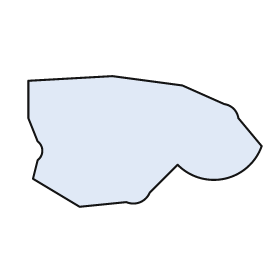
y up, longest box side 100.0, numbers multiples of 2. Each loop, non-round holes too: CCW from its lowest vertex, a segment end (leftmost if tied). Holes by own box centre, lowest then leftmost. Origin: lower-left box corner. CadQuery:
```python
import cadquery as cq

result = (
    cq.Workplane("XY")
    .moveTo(22.0, 0.0)
    .lineTo(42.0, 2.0)
    .threePointArc((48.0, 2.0), (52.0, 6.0))
    .lineTo(64.0, 18.0)
    .threePointArc((84.0, 12.0), (100.0, 26.0))
    .lineTo(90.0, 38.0)
    .threePointArc((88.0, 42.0), (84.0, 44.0))
    .lineTo(66.0, 52.0)
    .lineTo(36.0, 56.0)
    .lineTo(0.0, 54.0)
    .lineTo(0.0, 38.0)
    .lineTo(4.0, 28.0)
    .threePointArc((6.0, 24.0), (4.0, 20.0))
    .lineTo(2.0, 12.0)
    .close()
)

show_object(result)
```